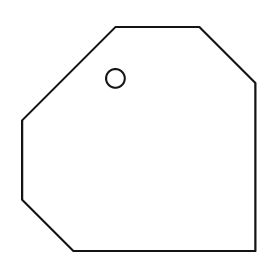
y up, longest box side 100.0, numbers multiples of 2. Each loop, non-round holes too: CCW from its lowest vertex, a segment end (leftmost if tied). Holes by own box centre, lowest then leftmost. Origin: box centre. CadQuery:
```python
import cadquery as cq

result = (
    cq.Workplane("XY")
    .moveTo(-28.0, -48.0)
    .lineTo(50.0, -48.0)
    .lineTo(50.0, 24.0)
    .lineTo(26.0, 48.0)
    .lineTo(-10.0, 48.0)
    .lineTo(-50.0, 8.0)
    .lineTo(-50.0, -26.0)
    .close()
    .moveTo(-10.0, 26.0)
    .circle(4.0)
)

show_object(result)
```